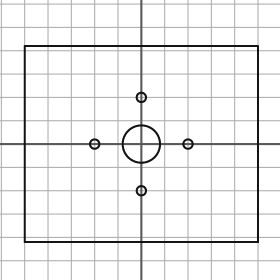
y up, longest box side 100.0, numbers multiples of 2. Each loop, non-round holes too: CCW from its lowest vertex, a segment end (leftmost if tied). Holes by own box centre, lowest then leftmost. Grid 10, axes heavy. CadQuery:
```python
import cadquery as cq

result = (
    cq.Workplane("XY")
    .moveTo(-50.0, -42.0)
    .lineTo(50.0, -42.0)
    .lineTo(50.0, 42.0)
    .lineTo(-50.0, 42.0)
    .close()
    .moveTo(0.0, -20.0)
    .circle(2.0)
    .moveTo(-20.0, 0.0)
    .circle(2.0)
    .moveTo(0.0, 0.0)
    .circle(8.0)
    .moveTo(20.0, 0.0)
    .circle(2.0)
    .moveTo(0.0, 20.0)
    .circle(2.0)
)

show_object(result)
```